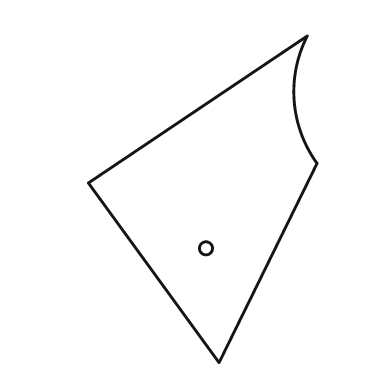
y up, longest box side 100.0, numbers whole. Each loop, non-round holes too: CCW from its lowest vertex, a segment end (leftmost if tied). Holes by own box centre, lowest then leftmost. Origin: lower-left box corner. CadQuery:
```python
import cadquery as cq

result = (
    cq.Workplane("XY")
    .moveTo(40.0, 0.0)
    .lineTo(70.0, 61.0)
    .threePointArc((63.0, 80.0), (67.0, 100.0))
    .lineTo(0.0, 55.0)
    .close()
    .moveTo(36.0, 35.0)
    .circle(2.0)
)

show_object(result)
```